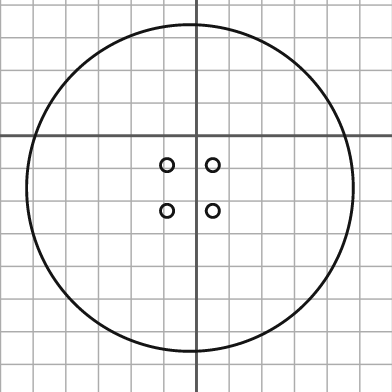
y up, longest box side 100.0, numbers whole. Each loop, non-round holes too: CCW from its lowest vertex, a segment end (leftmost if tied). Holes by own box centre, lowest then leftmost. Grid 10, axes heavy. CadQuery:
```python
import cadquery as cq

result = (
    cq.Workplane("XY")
    .moveTo(-2.0, -16.0)
    .circle(50.0)
    .moveTo(-9.0, -23.0)
    .circle(2.0)
    .moveTo(5.0, -23.0)
    .circle(2.0)
    .moveTo(-9.0, -9.0)
    .circle(2.0)
    .moveTo(5.0, -9.0)
    .circle(2.0)
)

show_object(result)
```